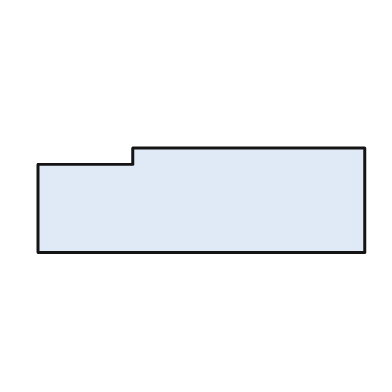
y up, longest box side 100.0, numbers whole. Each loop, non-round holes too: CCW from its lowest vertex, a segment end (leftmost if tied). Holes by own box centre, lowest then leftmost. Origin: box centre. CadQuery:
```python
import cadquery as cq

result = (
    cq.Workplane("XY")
    .moveTo(-50.0, -16.0)
    .lineTo(50.0, -16.0)
    .lineTo(50.0, 16.0)
    .lineTo(-21.0, 16.0)
    .lineTo(-21.0, 11.0)
    .lineTo(-50.0, 11.0)
    .close()
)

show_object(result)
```